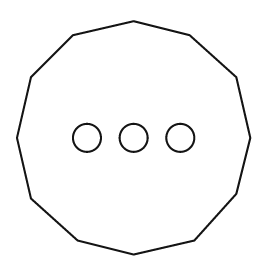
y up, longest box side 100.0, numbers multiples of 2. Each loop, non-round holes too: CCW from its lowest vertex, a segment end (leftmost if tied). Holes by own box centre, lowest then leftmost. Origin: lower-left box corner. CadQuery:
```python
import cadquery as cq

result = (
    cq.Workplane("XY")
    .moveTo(50.0, 0.0)
    .lineTo(76.0, 6.0)
    .lineTo(94.0, 26.0)
    .lineTo(100.0, 50.0)
    .lineTo(94.0, 76.0)
    .lineTo(74.0, 94.0)
    .lineTo(50.0, 100.0)
    .lineTo(24.0, 94.0)
    .lineTo(6.0, 76.0)
    .lineTo(0.0, 50.0)
    .lineTo(6.0, 24.0)
    .lineTo(26.0, 6.0)
    .close()
    .moveTo(30.0, 50.0)
    .circle(6.0)
    .moveTo(50.0, 50.0)
    .circle(6.0)
    .moveTo(70.0, 50.0)
    .circle(6.0)
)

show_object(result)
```